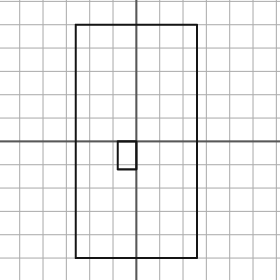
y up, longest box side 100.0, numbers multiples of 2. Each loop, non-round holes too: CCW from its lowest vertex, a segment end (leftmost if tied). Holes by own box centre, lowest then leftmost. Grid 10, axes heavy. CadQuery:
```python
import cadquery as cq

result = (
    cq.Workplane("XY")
    .moveTo(-26.0, -50.0)
    .lineTo(26.0, -50.0)
    .lineTo(26.0, 50.0)
    .lineTo(-26.0, 50.0)
    .close()
    .moveTo(-8.0, -12.0)
    .lineTo(0.0, -12.0)
    .lineTo(0.0, 0.0)
    .lineTo(-8.0, 0.0)
    .close()
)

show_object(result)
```